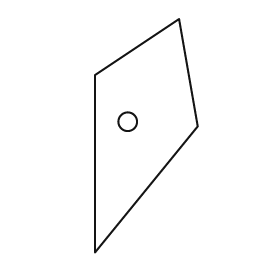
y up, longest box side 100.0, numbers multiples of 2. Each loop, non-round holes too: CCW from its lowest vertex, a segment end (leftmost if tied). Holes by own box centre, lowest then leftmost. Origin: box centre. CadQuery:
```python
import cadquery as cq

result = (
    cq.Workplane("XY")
    .moveTo(-22.0, -50.0)
    .lineTo(22.0, 4.0)
    .lineTo(14.0, 50.0)
    .lineTo(-22.0, 26.0)
    .close()
    .moveTo(-8.0, 6.0)
    .circle(4.0)
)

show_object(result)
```